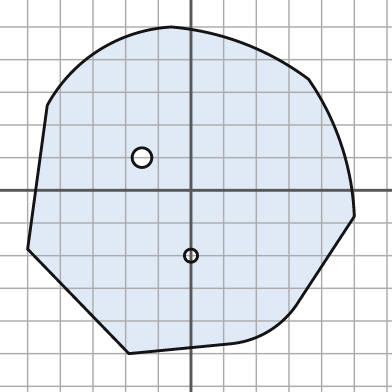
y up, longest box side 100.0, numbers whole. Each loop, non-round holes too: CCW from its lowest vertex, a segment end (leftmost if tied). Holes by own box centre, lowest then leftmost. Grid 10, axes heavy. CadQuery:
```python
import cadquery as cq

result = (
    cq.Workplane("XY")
    .moveTo(-19.0, -50.0)
    .lineTo(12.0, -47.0)
    .threePointArc((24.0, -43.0), (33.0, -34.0))
    .lineTo(50.0, -8.0)
    .threePointArc((46.0, 14.0), (36.0, 34.0))
    .threePointArc((16.0, 45.0), (-6.0, 50.0))
    .threePointArc((-28.0, 43.0), (-44.0, 26.0))
    .lineTo(-50.0, -18.0)
    .close()
    .moveTo(0.0, -20.0)
    .circle(2.0)
    .moveTo(-15.0, 10.0)
    .circle(3.0)
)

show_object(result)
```